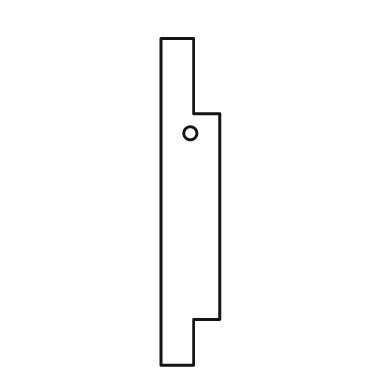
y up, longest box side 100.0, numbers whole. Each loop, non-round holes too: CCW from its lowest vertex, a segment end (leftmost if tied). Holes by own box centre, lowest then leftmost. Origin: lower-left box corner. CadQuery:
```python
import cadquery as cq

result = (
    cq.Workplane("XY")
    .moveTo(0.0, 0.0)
    .lineTo(10.0, 0.0)
    .lineTo(10.0, 14.0)
    .lineTo(18.0, 14.0)
    .lineTo(18.0, 77.0)
    .lineTo(10.0, 77.0)
    .lineTo(10.0, 100.0)
    .lineTo(0.0, 100.0)
    .close()
    .moveTo(9.0, 71.0)
    .circle(2.0)
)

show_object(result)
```